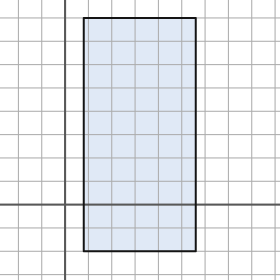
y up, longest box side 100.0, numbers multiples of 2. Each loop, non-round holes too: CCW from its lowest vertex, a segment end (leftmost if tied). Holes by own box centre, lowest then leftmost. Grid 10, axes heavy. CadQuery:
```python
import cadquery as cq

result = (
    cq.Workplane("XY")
    .moveTo(8.0, -20.0)
    .lineTo(56.0, -20.0)
    .lineTo(56.0, 80.0)
    .lineTo(8.0, 80.0)
    .close()
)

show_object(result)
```